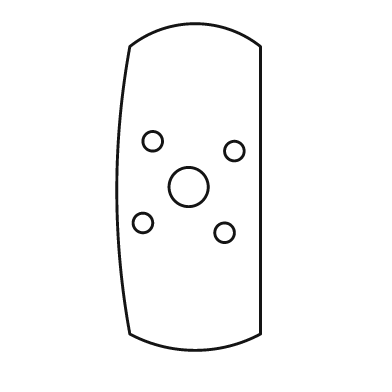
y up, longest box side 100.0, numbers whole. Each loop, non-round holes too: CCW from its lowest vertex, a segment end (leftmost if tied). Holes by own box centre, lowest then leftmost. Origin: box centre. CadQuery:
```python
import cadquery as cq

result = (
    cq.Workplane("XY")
    .moveTo(-18.0, -45.0)
    .threePointArc((2.0, -50.0), (22.0, -45.0))
    .lineTo(22.0, 43.0)
    .threePointArc((2.0, 50.0), (-18.0, 43.0))
    .threePointArc((-22.0, -1.0), (-18.0, -45.0))
    .close()
    .moveTo(11.0, -14.0)
    .circle(3.0)
    .moveTo(-14.0, -11.0)
    .circle(3.0)
    .moveTo(0.0, 0.0)
    .circle(6.0)
    .moveTo(14.0, 11.0)
    .circle(3.0)
    .moveTo(-11.0, 14.0)
    .circle(3.0)
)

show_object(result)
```